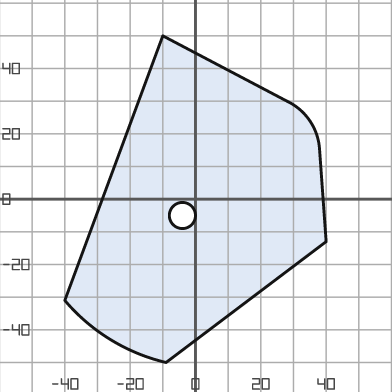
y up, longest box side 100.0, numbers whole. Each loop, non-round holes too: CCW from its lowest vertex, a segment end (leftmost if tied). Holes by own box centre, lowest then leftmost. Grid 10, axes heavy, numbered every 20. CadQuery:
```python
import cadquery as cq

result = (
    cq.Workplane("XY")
    .moveTo(-9.0, -50.0)
    .lineTo(40.0, -13.0)
    .lineTo(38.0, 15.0)
    .threePointArc((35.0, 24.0), (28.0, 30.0))
    .lineTo(-10.0, 50.0)
    .lineTo(-40.0, -31.0)
    .threePointArc((-26.0, -43.0), (-9.0, -50.0))
    .close()
    .moveTo(-4.0, -5.0)
    .circle(4.0)
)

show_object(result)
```